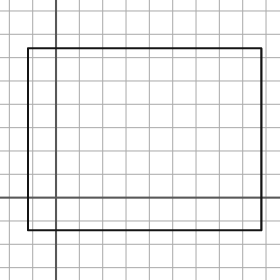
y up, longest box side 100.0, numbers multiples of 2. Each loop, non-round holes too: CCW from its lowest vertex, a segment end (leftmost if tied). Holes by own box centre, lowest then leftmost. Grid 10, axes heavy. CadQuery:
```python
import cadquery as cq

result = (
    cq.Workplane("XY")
    .moveTo(-12.0, -14.0)
    .lineTo(88.0, -14.0)
    .lineTo(88.0, 64.0)
    .lineTo(-12.0, 64.0)
    .close()
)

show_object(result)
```